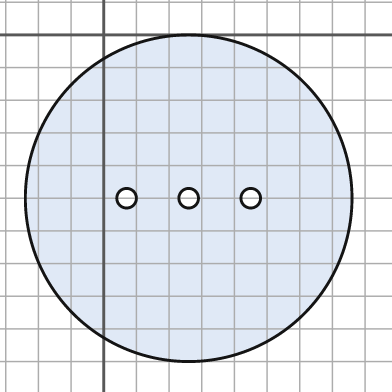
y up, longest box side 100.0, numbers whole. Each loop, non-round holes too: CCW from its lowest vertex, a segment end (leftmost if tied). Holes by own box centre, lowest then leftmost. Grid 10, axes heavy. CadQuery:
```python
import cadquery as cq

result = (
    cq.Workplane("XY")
    .moveTo(26.0, -50.0)
    .circle(50.0)
    .moveTo(7.0, -50.0)
    .circle(3.0)
    .moveTo(26.0, -50.0)
    .circle(3.0)
    .moveTo(45.0, -50.0)
    .circle(3.0)
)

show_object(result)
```